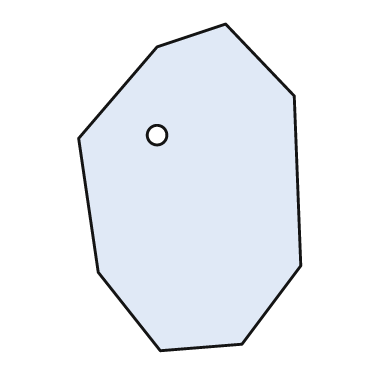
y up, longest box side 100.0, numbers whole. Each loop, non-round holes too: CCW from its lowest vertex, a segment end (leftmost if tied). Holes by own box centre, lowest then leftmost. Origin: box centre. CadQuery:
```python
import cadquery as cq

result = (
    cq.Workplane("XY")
    .moveTo(-9.0, -50.0)
    .lineTo(16.0, -48.0)
    .lineTo(34.0, -24.0)
    .lineTo(32.0, 28.0)
    .lineTo(11.0, 50.0)
    .lineTo(-10.0, 43.0)
    .lineTo(-34.0, 15.0)
    .lineTo(-28.0, -26.0)
    .close()
    .moveTo(-10.0, 16.0)
    .circle(3.0)
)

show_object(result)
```